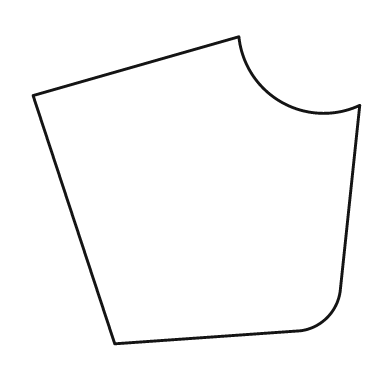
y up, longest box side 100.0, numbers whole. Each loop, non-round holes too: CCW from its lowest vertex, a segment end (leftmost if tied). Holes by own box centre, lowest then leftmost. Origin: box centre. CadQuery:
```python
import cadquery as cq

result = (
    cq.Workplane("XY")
    .moveTo(-25.0, -47.0)
    .lineTo(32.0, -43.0)
    .threePointArc((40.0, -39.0), (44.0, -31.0))
    .lineTo(50.0, 26.0)
    .threePointArc((26.0, 27.0), (13.0, 47.0))
    .lineTo(-50.0, 29.0)
    .close()
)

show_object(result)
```